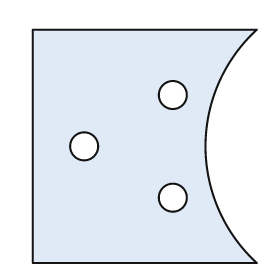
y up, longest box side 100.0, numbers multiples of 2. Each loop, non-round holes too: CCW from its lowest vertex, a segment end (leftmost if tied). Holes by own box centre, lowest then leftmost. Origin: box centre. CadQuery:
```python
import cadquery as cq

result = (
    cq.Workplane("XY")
    .moveTo(-48.0, -50.0)
    .lineTo(48.0, -50.0)
    .threePointArc((26.0, 0.0), (48.0, 50.0))
    .lineTo(-48.0, 50.0)
    .close()
    .moveTo(12.0, -22.0)
    .circle(6.0)
    .moveTo(-26.0, 0.0)
    .circle(6.0)
    .moveTo(12.0, 22.0)
    .circle(6.0)
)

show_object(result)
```